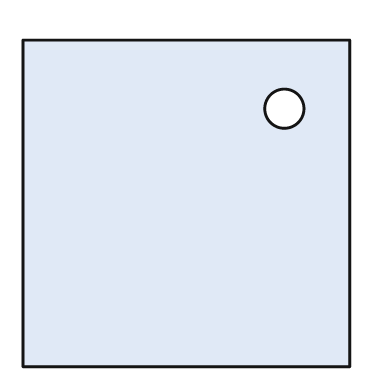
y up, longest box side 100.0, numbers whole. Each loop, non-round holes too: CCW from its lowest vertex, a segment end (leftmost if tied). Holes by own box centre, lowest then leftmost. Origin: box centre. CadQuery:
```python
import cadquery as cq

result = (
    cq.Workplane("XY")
    .moveTo(-50.0, -50.0)
    .lineTo(50.0, -50.0)
    .lineTo(50.0, 50.0)
    .lineTo(-50.0, 50.0)
    .close()
    .moveTo(30.0, 29.0)
    .circle(6.0)
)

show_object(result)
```